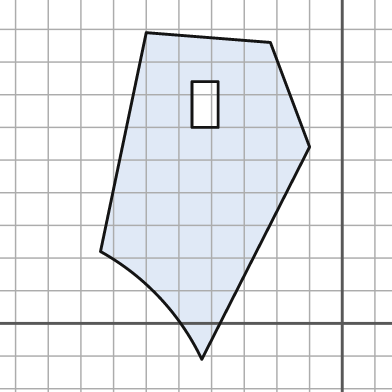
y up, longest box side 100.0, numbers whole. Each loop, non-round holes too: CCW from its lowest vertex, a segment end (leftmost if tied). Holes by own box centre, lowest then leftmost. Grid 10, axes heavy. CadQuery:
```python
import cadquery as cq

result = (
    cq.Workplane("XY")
    .moveTo(-43.0, -11.0)
    .lineTo(-10.0, 54.0)
    .lineTo(-22.0, 86.0)
    .lineTo(-60.0, 89.0)
    .lineTo(-74.0, 22.0)
    .threePointArc((-56.0, 8.0), (-43.0, -11.0))
    .close()
    .moveTo(-46.0, 60.0)
    .lineTo(-38.0, 60.0)
    .lineTo(-38.0, 74.0)
    .lineTo(-46.0, 74.0)
    .close()
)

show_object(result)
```